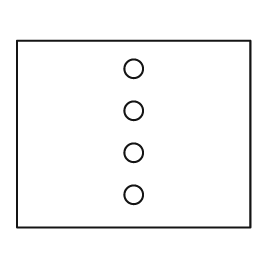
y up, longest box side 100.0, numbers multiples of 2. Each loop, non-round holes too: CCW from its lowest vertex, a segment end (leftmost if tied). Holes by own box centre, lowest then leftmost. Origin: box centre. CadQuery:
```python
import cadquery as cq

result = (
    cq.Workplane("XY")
    .moveTo(-50.0, -40.0)
    .lineTo(50.0, -40.0)
    .lineTo(50.0, 40.0)
    .lineTo(-50.0, 40.0)
    .close()
    .moveTo(0.0, -26.0)
    .circle(4.0)
    .moveTo(0.0, -8.0)
    .circle(4.0)
    .moveTo(0.0, 10.0)
    .circle(4.0)
    .moveTo(0.0, 28.0)
    .circle(4.0)
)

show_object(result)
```